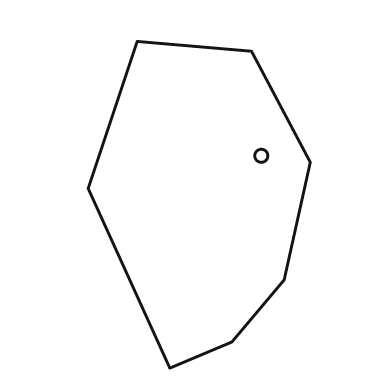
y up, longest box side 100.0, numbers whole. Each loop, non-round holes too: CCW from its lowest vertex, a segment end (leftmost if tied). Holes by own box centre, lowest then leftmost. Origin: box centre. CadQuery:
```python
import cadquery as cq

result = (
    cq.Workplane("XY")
    .moveTo(-9.0, -50.0)
    .lineTo(10.0, -42.0)
    .lineTo(26.0, -23.0)
    .lineTo(34.0, 13.0)
    .lineTo(16.0, 47.0)
    .lineTo(-19.0, 50.0)
    .lineTo(-34.0, 5.0)
    .close()
    .moveTo(19.0, 15.0)
    .circle(2.0)
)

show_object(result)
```